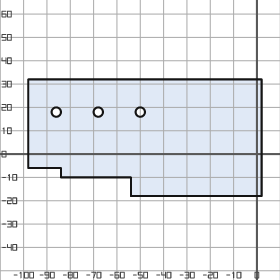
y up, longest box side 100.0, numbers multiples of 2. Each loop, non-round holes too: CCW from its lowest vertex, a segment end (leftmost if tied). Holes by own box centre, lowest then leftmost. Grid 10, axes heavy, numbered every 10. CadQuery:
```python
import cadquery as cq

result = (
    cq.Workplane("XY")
    .moveTo(-54.0, -18.0)
    .lineTo(2.0, -18.0)
    .lineTo(2.0, 32.0)
    .lineTo(-98.0, 32.0)
    .lineTo(-98.0, -6.0)
    .lineTo(-84.0, -6.0)
    .lineTo(-84.0, -10.0)
    .lineTo(-54.0, -10.0)
    .close()
    .moveTo(-86.0, 18.0)
    .circle(2.0)
    .moveTo(-68.0, 18.0)
    .circle(2.0)
    .moveTo(-50.0, 18.0)
    .circle(2.0)
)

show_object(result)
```